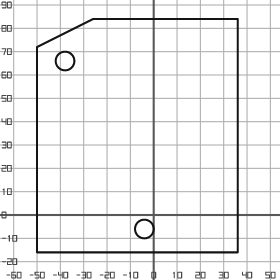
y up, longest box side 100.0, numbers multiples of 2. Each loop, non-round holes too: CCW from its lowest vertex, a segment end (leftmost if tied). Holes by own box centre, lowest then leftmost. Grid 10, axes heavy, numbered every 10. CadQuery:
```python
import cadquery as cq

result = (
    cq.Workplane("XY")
    .moveTo(-50.0, -16.0)
    .lineTo(36.0, -16.0)
    .lineTo(36.0, 84.0)
    .lineTo(-26.0, 84.0)
    .lineTo(-50.0, 72.0)
    .close()
    .moveTo(-4.0, -6.0)
    .circle(4.0)
    .moveTo(-38.0, 66.0)
    .circle(4.0)
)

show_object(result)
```